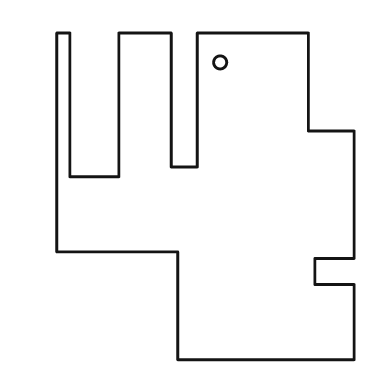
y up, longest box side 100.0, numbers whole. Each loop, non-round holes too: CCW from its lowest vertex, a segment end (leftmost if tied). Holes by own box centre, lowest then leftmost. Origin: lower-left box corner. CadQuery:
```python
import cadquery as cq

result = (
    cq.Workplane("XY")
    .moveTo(37.0, 0.0)
    .lineTo(91.0, 0.0)
    .lineTo(91.0, 23.0)
    .lineTo(79.0, 23.0)
    .lineTo(79.0, 31.0)
    .lineTo(91.0, 31.0)
    .lineTo(91.0, 70.0)
    .lineTo(77.0, 70.0)
    .lineTo(77.0, 100.0)
    .lineTo(43.0, 100.0)
    .lineTo(43.0, 59.0)
    .lineTo(35.0, 59.0)
    .lineTo(35.0, 100.0)
    .lineTo(19.0, 100.0)
    .lineTo(19.0, 56.0)
    .lineTo(4.0, 56.0)
    .lineTo(4.0, 100.0)
    .lineTo(0.0, 100.0)
    .lineTo(0.0, 33.0)
    .lineTo(37.0, 33.0)
    .close()
    .moveTo(50.0, 91.0)
    .circle(2.0)
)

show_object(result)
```